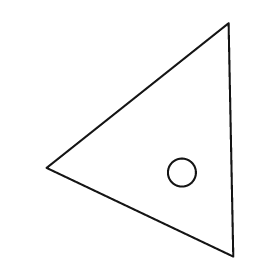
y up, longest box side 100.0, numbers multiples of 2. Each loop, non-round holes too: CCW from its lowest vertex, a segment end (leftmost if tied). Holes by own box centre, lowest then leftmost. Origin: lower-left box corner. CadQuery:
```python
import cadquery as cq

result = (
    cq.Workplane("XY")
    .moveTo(80.0, 0.0)
    .lineTo(78.0, 100.0)
    .lineTo(0.0, 38.0)
    .close()
    .moveTo(58.0, 36.0)
    .circle(6.0)
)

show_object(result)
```